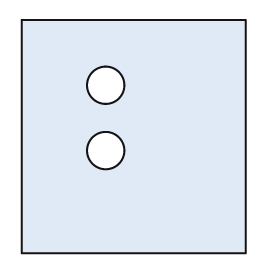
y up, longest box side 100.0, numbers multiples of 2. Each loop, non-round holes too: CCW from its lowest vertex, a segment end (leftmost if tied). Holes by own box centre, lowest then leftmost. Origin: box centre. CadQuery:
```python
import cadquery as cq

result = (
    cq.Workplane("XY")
    .moveTo(-48.0, -50.0)
    .lineTo(48.0, -50.0)
    .lineTo(48.0, 50.0)
    .lineTo(-48.0, 50.0)
    .close()
    .moveTo(-12.0, -6.0)
    .circle(8.0)
    .moveTo(-12.0, 22.0)
    .circle(8.0)
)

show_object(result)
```